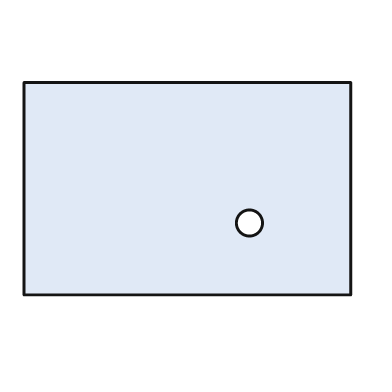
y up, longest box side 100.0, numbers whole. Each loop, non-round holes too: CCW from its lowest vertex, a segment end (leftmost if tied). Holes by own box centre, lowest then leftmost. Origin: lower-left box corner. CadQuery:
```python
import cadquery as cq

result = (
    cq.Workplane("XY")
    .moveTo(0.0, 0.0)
    .lineTo(100.0, 0.0)
    .lineTo(100.0, 65.0)
    .lineTo(0.0, 65.0)
    .close()
    .moveTo(69.0, 22.0)
    .circle(4.0)
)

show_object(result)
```